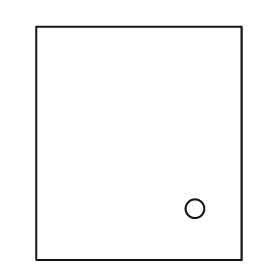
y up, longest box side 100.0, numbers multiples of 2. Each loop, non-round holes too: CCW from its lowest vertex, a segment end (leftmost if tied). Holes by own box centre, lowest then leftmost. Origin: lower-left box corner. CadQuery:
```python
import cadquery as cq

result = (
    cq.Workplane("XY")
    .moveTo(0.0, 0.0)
    .lineTo(88.0, 0.0)
    .lineTo(88.0, 100.0)
    .lineTo(0.0, 100.0)
    .close()
    .moveTo(68.0, 22.0)
    .circle(4.0)
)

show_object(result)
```